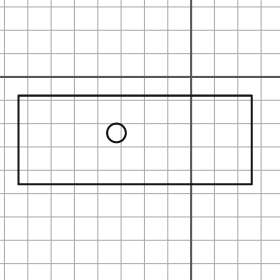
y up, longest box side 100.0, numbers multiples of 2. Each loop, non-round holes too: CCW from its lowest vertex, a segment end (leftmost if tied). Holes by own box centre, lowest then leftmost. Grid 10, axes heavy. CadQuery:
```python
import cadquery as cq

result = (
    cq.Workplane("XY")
    .moveTo(-74.0, -46.0)
    .lineTo(26.0, -46.0)
    .lineTo(26.0, -8.0)
    .lineTo(-74.0, -8.0)
    .close()
    .moveTo(-32.0, -24.0)
    .circle(4.0)
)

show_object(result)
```